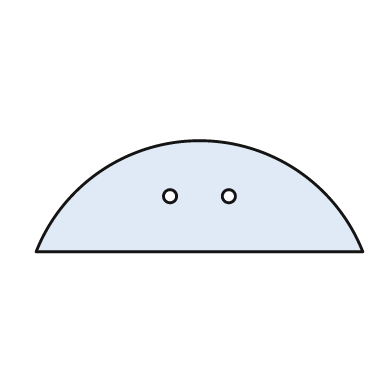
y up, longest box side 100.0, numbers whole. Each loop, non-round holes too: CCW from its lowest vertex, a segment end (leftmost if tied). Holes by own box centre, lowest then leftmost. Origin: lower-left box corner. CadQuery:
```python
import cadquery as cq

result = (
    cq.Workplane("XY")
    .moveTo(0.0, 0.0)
    .lineTo(100.0, 0.0)
    .threePointArc((50.0, 34.0), (0.0, 0.0))
    .close()
    .moveTo(41.0, 17.0)
    .circle(2.0)
    .moveTo(59.0, 17.0)
    .circle(2.0)
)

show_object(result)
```